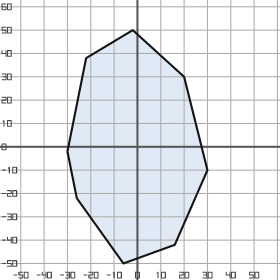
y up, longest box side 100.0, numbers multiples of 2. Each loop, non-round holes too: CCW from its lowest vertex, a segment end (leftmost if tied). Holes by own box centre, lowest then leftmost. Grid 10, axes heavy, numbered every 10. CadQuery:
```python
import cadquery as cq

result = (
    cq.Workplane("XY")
    .moveTo(-6.0, -50.0)
    .lineTo(16.0, -42.0)
    .lineTo(30.0, -10.0)
    .lineTo(20.0, 30.0)
    .lineTo(-2.0, 50.0)
    .lineTo(-22.0, 38.0)
    .lineTo(-30.0, -2.0)
    .lineTo(-26.0, -22.0)
    .close()
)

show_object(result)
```